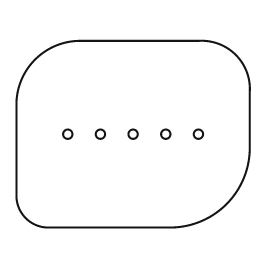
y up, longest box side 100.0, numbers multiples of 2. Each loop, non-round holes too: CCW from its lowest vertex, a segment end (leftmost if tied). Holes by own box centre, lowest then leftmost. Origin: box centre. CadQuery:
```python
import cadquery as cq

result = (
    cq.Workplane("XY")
    .moveTo(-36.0, -40.0)
    .lineTo(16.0, -40.0)
    .threePointArc((40.0, -30.0), (50.0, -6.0))
    .lineTo(50.0, 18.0)
    .threePointArc((44.0, 34.0), (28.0, 40.0))
    .lineTo(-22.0, 40.0)
    .threePointArc((-42.0, 32.0), (-50.0, 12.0))
    .lineTo(-50.0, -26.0)
    .threePointArc((-46.0, -36.0), (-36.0, -40.0))
    .close()
    .moveTo(-28.0, 0.0)
    .circle(2.0)
    .moveTo(-14.0, 0.0)
    .circle(2.0)
    .moveTo(0.0, 0.0)
    .circle(2.0)
    .moveTo(14.0, 0.0)
    .circle(2.0)
    .moveTo(28.0, 0.0)
    .circle(2.0)
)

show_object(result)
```